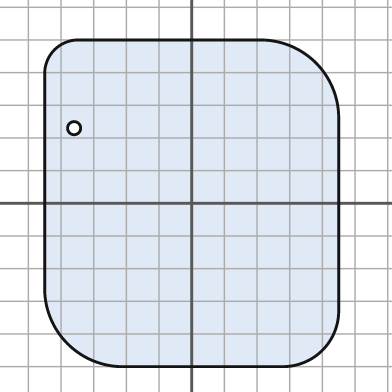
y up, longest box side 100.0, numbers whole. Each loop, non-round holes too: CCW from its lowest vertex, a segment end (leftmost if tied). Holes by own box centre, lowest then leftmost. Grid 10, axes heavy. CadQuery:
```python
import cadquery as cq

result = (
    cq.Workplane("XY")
    .moveTo(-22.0, -50.0)
    .lineTo(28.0, -50.0)
    .threePointArc((40.0, -45.0), (45.0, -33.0))
    .lineTo(45.0, 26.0)
    .threePointArc((38.0, 43.0), (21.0, 50.0))
    .lineTo(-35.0, 50.0)
    .threePointArc((-42.0, 47.0), (-45.0, 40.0))
    .lineTo(-45.0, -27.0)
    .threePointArc((-38.0, -43.0), (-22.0, -50.0))
    .close()
    .moveTo(-36.0, 23.0)
    .circle(2.0)
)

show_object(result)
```